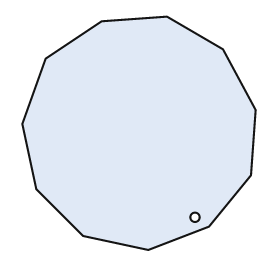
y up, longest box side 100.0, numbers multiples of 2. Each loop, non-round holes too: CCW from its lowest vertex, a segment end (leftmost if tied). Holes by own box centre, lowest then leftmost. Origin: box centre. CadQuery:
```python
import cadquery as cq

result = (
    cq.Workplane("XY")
    .moveTo(4.0, -50.0)
    .lineTo(30.0, -40.0)
    .lineTo(48.0, -18.0)
    .lineTo(50.0, 10.0)
    .lineTo(36.0, 36.0)
    .lineTo(12.0, 50.0)
    .lineTo(-16.0, 48.0)
    .lineTo(-40.0, 32.0)
    .lineTo(-50.0, 4.0)
    .lineTo(-44.0, -24.0)
    .lineTo(-24.0, -44.0)
    .close()
    .moveTo(24.0, -36.0)
    .circle(2.0)
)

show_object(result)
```